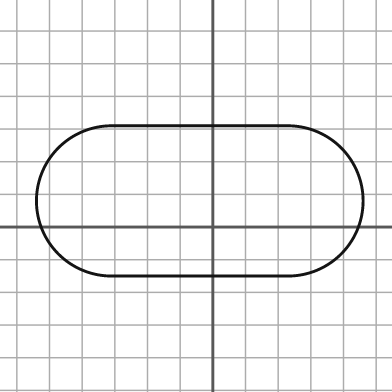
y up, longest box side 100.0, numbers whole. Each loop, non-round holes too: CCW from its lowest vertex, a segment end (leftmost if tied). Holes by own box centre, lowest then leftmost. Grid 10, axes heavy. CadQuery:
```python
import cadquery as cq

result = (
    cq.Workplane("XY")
    .moveTo(-31.0, -15.0)
    .lineTo(23.0, -15.0)
    .threePointArc((46.0, 8.0), (23.0, 31.0))
    .lineTo(-31.0, 31.0)
    .threePointArc((-54.0, 8.0), (-31.0, -15.0))
    .close()
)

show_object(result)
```